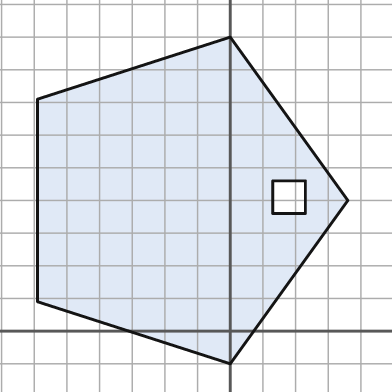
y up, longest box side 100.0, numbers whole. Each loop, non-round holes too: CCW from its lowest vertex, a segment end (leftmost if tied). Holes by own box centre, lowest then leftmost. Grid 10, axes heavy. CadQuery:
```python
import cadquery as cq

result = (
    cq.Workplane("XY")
    .moveTo(0.0, -10.0)
    .lineTo(36.0, 40.0)
    .lineTo(0.0, 90.0)
    .lineTo(-59.0, 71.0)
    .lineTo(-59.0, 9.0)
    .close()
    .moveTo(13.0, 36.0)
    .lineTo(23.0, 36.0)
    .lineTo(23.0, 46.0)
    .lineTo(13.0, 46.0)
    .close()
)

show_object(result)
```